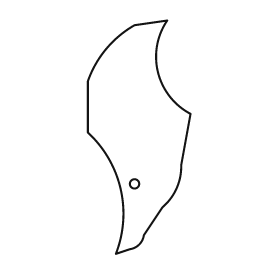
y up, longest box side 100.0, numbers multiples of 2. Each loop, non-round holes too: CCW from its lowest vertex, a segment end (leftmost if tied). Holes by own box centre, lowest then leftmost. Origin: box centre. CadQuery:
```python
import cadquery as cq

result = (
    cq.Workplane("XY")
    .moveTo(-10.0, -50.0)
    .lineTo(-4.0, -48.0)
    .threePointArc((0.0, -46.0), (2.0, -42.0))
    .lineTo(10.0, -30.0)
    .threePointArc((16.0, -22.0), (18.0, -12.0))
    .lineTo(22.0, 10.0)
    .threePointArc((8.0, 28.0), (12.0, 50.0))
    .lineTo(-2.0, 48.0)
    .threePointArc((-14.0, 38.0), (-22.0, 24.0))
    .lineTo(-22.0, 2.0)
    .threePointArc((-8.0, -22.0), (-10.0, -50.0))
    .close()
    .moveTo(-2.0, -20.0)
    .circle(2.0)
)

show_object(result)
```